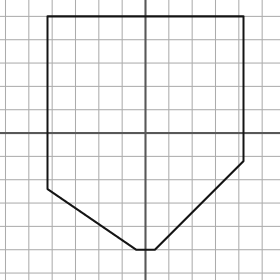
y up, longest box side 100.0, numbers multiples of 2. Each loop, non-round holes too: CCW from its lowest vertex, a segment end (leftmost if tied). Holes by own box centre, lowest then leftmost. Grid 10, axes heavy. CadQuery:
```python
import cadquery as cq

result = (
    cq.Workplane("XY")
    .moveTo(-4.0, -50.0)
    .lineTo(4.0, -50.0)
    .lineTo(42.0, -12.0)
    .lineTo(42.0, 50.0)
    .lineTo(-42.0, 50.0)
    .lineTo(-42.0, -24.0)
    .close()
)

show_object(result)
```